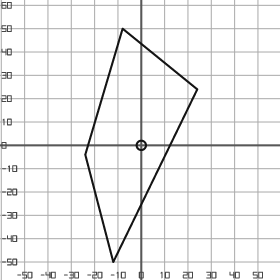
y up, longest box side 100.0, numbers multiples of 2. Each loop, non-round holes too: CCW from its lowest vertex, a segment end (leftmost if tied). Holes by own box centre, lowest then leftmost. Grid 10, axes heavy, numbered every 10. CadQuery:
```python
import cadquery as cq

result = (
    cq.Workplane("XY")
    .moveTo(-12.0, -50.0)
    .lineTo(24.0, 24.0)
    .lineTo(-8.0, 50.0)
    .lineTo(-24.0, -4.0)
    .close()
    .moveTo(0.0, 0.0)
    .circle(2.0)
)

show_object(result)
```